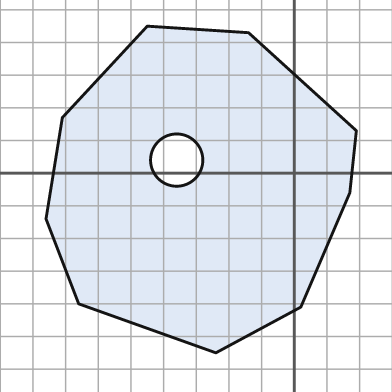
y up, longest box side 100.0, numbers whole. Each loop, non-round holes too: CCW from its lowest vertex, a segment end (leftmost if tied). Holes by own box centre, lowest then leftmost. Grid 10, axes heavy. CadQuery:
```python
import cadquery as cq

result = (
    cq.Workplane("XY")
    .moveTo(-24.0, -55.0)
    .lineTo(2.0, -41.0)
    .lineTo(17.0, -6.0)
    .lineTo(19.0, 13.0)
    .lineTo(-14.0, 43.0)
    .lineTo(-45.0, 45.0)
    .lineTo(-71.0, 17.0)
    .lineTo(-76.0, -14.0)
    .lineTo(-66.0, -40.0)
    .close()
    .moveTo(-36.0, 4.0)
    .circle(8.0)
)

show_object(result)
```